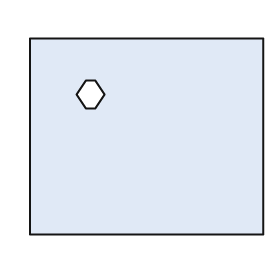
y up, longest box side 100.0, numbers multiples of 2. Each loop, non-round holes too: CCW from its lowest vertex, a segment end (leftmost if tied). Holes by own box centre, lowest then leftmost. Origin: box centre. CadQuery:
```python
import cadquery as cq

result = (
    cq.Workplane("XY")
    .moveTo(-50.0, -42.0)
    .lineTo(50.0, -42.0)
    .lineTo(50.0, 42.0)
    .lineTo(-50.0, 42.0)
    .close()
    .moveTo(-26.0, 12.0)
    .lineTo(-22.0, 12.0)
    .lineTo(-18.0, 18.0)
    .lineTo(-22.0, 24.0)
    .lineTo(-26.0, 24.0)
    .lineTo(-30.0, 18.0)
    .close()
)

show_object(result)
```